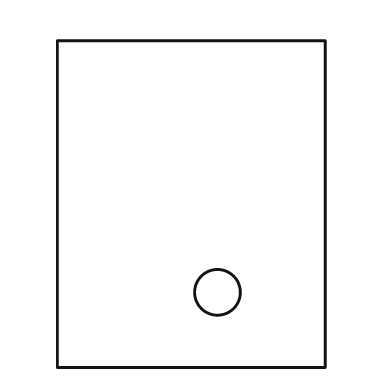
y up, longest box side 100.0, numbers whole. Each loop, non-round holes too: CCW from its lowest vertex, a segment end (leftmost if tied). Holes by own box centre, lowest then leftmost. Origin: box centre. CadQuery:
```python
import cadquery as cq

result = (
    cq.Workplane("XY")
    .moveTo(-41.0, -50.0)
    .lineTo(41.0, -50.0)
    .lineTo(41.0, 50.0)
    .lineTo(-41.0, 50.0)
    .close()
    .moveTo(8.0, -27.0)
    .circle(7.0)
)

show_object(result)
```